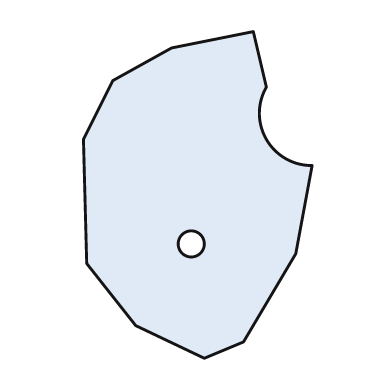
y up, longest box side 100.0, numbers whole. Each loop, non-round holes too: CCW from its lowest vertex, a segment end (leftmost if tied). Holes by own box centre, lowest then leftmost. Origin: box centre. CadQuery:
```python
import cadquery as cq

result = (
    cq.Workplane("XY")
    .moveTo(2.0, -50.0)
    .lineTo(14.0, -45.0)
    .lineTo(30.0, -18.0)
    .lineTo(35.0, 9.0)
    .threePointArc((21.0, 17.0), (21.0, 33.0))
    .lineTo(17.0, 50.0)
    .lineTo(-8.0, 45.0)
    .lineTo(-26.0, 35.0)
    .lineTo(-35.0, 17.0)
    .lineTo(-34.0, -21.0)
    .lineTo(-19.0, -40.0)
    .close()
    .moveTo(-2.0, -15.0)
    .circle(4.0)
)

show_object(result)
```